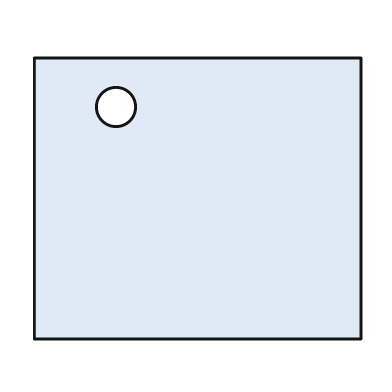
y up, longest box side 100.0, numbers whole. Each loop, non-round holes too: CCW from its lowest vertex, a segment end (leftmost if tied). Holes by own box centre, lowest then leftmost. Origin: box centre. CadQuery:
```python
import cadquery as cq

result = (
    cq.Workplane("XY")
    .moveTo(-50.0, -43.0)
    .lineTo(50.0, -43.0)
    .lineTo(50.0, 43.0)
    .lineTo(-50.0, 43.0)
    .close()
    .moveTo(-25.0, 28.0)
    .circle(6.0)
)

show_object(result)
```